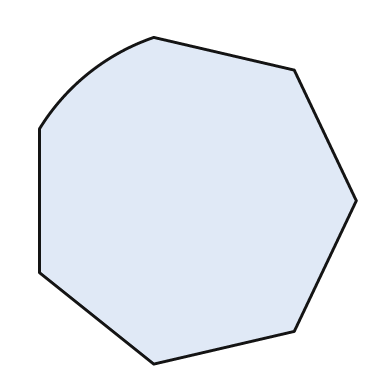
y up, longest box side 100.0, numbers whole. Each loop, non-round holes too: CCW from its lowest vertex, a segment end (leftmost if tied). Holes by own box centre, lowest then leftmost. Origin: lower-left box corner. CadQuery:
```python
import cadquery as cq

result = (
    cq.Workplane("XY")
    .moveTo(35.0, 0.0)
    .lineTo(78.0, 10.0)
    .lineTo(97.0, 50.0)
    .lineTo(78.0, 90.0)
    .lineTo(35.0, 100.0)
    .threePointArc((15.0, 89.0), (0.0, 72.0))
    .lineTo(0.0, 28.0)
    .close()
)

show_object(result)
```